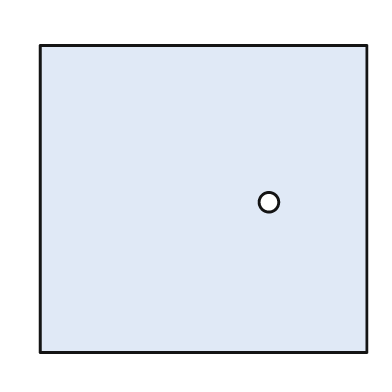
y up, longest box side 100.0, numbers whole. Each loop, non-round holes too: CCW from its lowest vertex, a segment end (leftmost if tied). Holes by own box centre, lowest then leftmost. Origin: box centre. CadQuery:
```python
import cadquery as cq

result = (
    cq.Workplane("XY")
    .moveTo(-50.0, -47.0)
    .lineTo(50.0, -47.0)
    .lineTo(50.0, 47.0)
    .lineTo(-50.0, 47.0)
    .close()
    .moveTo(20.0, -1.0)
    .circle(3.0)
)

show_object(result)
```